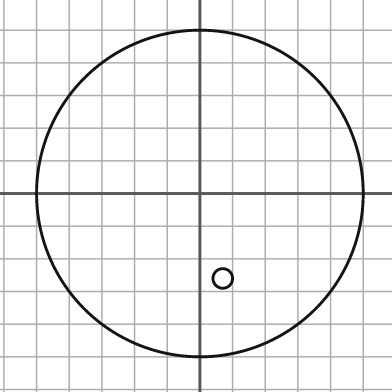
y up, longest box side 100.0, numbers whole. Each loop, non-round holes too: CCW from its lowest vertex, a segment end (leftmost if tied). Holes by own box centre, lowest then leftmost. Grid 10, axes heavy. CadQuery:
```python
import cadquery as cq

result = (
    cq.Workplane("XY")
    .moveTo(0.0, 0.0)
    .circle(50.0)
    .moveTo(7.0, -26.0)
    .circle(3.0)
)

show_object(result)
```